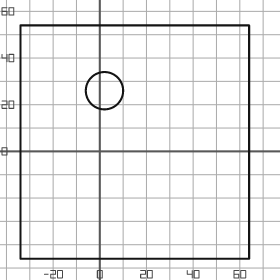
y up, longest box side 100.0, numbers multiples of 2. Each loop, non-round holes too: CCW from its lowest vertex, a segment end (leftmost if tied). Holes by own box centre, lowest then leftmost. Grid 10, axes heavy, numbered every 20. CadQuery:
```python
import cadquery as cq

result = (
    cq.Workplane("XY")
    .moveTo(-34.0, -46.0)
    .lineTo(64.0, -46.0)
    .lineTo(64.0, 54.0)
    .lineTo(-34.0, 54.0)
    .close()
    .moveTo(2.0, 26.0)
    .circle(8.0)
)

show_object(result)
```